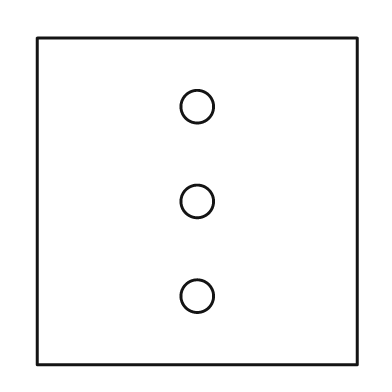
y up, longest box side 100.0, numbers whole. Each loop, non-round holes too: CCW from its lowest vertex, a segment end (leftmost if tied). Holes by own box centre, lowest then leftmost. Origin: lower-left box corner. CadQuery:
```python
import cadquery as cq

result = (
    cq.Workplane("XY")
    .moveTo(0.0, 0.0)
    .lineTo(98.0, 0.0)
    .lineTo(98.0, 100.0)
    .lineTo(0.0, 100.0)
    .close()
    .moveTo(49.0, 21.0)
    .circle(5.0)
    .moveTo(49.0, 50.0)
    .circle(5.0)
    .moveTo(49.0, 79.0)
    .circle(5.0)
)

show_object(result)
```